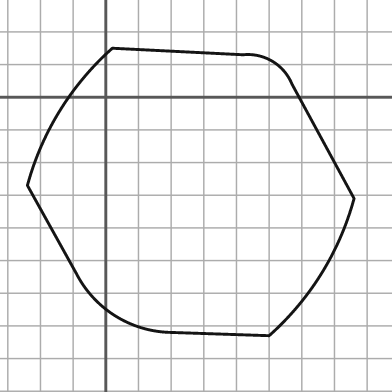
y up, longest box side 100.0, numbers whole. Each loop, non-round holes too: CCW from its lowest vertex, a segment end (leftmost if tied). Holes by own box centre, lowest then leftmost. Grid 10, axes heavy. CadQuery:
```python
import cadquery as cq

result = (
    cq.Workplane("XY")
    .moveTo(50.0, -73.0)
    .threePointArc((66.0, -54.0), (76.0, -31.0))
    .lineTo(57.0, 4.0)
    .threePointArc((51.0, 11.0), (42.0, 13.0))
    .lineTo(2.0, 15.0)
    .threePointArc((-14.0, -4.0), (-24.0, -27.0))
    .lineTo(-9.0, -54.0)
    .threePointArc((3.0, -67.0), (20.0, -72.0))
    .close()
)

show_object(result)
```